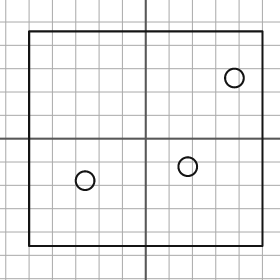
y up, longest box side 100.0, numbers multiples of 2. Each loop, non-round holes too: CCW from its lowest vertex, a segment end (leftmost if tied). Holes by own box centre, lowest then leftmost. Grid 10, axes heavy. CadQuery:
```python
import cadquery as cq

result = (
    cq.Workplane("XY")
    .moveTo(-50.0, -46.0)
    .lineTo(50.0, -46.0)
    .lineTo(50.0, 46.0)
    .lineTo(-50.0, 46.0)
    .close()
    .moveTo(-26.0, -18.0)
    .circle(4.0)
    .moveTo(18.0, -12.0)
    .circle(4.0)
    .moveTo(38.0, 26.0)
    .circle(4.0)
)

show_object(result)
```